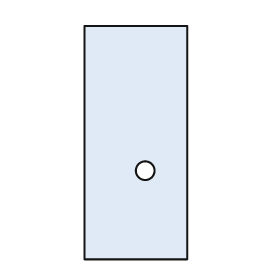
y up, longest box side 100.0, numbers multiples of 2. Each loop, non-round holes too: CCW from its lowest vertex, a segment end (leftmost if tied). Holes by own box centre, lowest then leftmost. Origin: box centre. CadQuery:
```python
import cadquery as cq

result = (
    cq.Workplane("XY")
    .moveTo(-22.0, -50.0)
    .lineTo(22.0, -50.0)
    .lineTo(22.0, 50.0)
    .lineTo(-22.0, 50.0)
    .close()
    .moveTo(4.0, -12.0)
    .circle(4.0)
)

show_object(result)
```